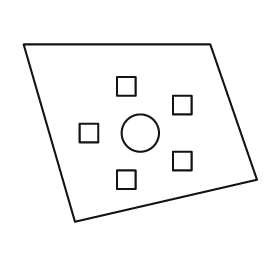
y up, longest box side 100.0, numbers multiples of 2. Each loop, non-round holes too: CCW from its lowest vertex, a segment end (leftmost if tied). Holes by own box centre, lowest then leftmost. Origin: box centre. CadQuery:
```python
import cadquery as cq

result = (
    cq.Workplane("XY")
    .moveTo(-28.0, -38.0)
    .lineTo(50.0, -20.0)
    .lineTo(30.0, 38.0)
    .lineTo(-50.0, 38.0)
    .close()
    .moveTo(-10.0, -24.0)
    .lineTo(-2.0, -24.0)
    .lineTo(-2.0, -16.0)
    .lineTo(-10.0, -16.0)
    .close()
    .moveTo(14.0, -16.0)
    .lineTo(22.0, -16.0)
    .lineTo(22.0, -8.0)
    .lineTo(14.0, -8.0)
    .close()
    .moveTo(-26.0, -4.0)
    .lineTo(-18.0, -4.0)
    .lineTo(-18.0, 4.0)
    .lineTo(-26.0, 4.0)
    .close()
    .moveTo(0.0, 0.0)
    .circle(8.0)
    .moveTo(14.0, 8.0)
    .lineTo(22.0, 8.0)
    .lineTo(22.0, 16.0)
    .lineTo(14.0, 16.0)
    .close()
    .moveTo(-10.0, 16.0)
    .lineTo(-2.0, 16.0)
    .lineTo(-2.0, 24.0)
    .lineTo(-10.0, 24.0)
    .close()
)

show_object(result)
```